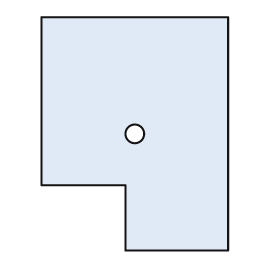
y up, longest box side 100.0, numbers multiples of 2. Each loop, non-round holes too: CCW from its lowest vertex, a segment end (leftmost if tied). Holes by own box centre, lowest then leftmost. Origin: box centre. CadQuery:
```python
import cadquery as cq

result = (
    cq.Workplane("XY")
    .moveTo(-4.0, -50.0)
    .lineTo(40.0, -50.0)
    .lineTo(40.0, 50.0)
    .lineTo(-40.0, 50.0)
    .lineTo(-40.0, -22.0)
    .lineTo(-4.0, -22.0)
    .close()
    .moveTo(0.0, 0.0)
    .circle(4.0)
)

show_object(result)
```